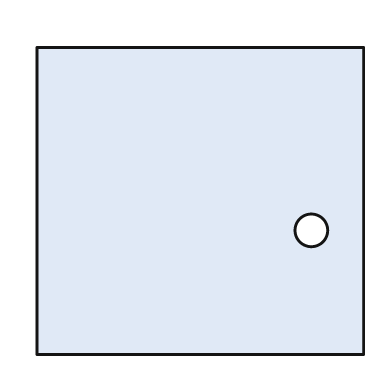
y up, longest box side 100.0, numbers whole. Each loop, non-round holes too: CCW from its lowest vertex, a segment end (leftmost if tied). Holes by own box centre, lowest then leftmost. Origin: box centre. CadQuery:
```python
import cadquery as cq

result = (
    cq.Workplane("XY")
    .moveTo(-50.0, -47.0)
    .lineTo(50.0, -47.0)
    .lineTo(50.0, 47.0)
    .lineTo(-50.0, 47.0)
    .close()
    .moveTo(34.0, -9.0)
    .circle(5.0)
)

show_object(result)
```